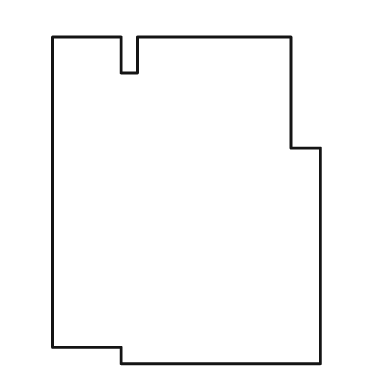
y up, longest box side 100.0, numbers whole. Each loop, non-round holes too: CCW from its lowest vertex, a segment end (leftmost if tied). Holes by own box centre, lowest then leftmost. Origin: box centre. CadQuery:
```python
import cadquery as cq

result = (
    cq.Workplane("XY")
    .moveTo(-20.0, -50.0)
    .lineTo(41.0, -50.0)
    .lineTo(41.0, 16.0)
    .lineTo(32.0, 16.0)
    .lineTo(32.0, 50.0)
    .lineTo(-15.0, 50.0)
    .lineTo(-15.0, 39.0)
    .lineTo(-20.0, 39.0)
    .lineTo(-20.0, 50.0)
    .lineTo(-41.0, 50.0)
    .lineTo(-41.0, -45.0)
    .lineTo(-20.0, -45.0)
    .close()
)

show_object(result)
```